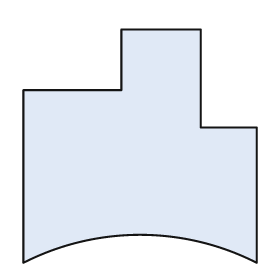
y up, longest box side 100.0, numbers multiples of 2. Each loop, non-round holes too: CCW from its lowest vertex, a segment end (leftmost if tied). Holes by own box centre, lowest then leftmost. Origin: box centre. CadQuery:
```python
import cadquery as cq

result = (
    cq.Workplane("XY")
    .moveTo(-50.0, -50.0)
    .threePointArc((0.0, -38.0), (50.0, -50.0))
    .lineTo(50.0, 8.0)
    .lineTo(26.0, 8.0)
    .lineTo(26.0, 50.0)
    .lineTo(-8.0, 50.0)
    .lineTo(-8.0, 24.0)
    .lineTo(-50.0, 24.0)
    .close()
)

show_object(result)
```